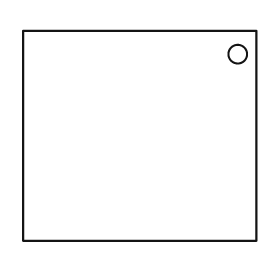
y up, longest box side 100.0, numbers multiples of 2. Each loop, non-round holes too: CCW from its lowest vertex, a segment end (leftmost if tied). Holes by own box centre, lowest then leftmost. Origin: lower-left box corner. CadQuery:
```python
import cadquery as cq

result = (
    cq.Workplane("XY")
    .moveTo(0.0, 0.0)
    .lineTo(100.0, 0.0)
    .lineTo(100.0, 90.0)
    .lineTo(0.0, 90.0)
    .close()
    .moveTo(92.0, 80.0)
    .circle(4.0)
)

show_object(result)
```